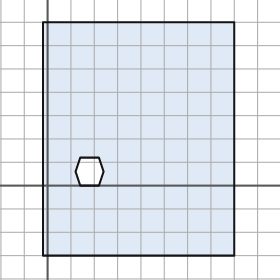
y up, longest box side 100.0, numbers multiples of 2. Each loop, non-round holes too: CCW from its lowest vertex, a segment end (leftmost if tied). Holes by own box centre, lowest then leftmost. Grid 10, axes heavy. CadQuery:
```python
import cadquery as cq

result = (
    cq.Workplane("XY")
    .moveTo(-2.0, -30.0)
    .lineTo(80.0, -30.0)
    .lineTo(80.0, 70.0)
    .lineTo(-2.0, 70.0)
    .close()
    .moveTo(14.0, 0.0)
    .lineTo(22.0, 0.0)
    .lineTo(24.0, 6.0)
    .lineTo(22.0, 12.0)
    .lineTo(14.0, 12.0)
    .lineTo(12.0, 6.0)
    .close()
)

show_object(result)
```